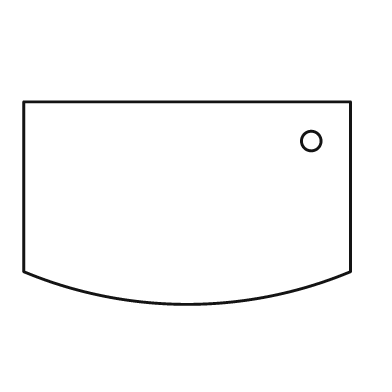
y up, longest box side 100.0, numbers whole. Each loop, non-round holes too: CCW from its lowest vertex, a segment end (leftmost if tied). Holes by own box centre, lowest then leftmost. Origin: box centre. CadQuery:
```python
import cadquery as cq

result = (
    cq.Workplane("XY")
    .moveTo(-50.0, -21.0)
    .threePointArc((0.0, -31.0), (50.0, -21.0))
    .lineTo(50.0, 31.0)
    .lineTo(-50.0, 31.0)
    .close()
    .moveTo(38.0, 19.0)
    .circle(3.0)
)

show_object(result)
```